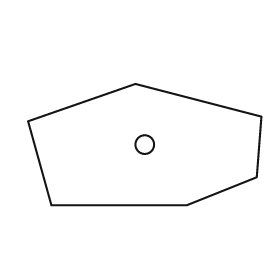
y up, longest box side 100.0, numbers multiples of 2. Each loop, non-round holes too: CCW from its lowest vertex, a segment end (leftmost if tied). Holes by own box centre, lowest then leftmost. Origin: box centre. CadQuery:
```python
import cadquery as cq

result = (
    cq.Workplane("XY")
    .moveTo(-40.0, -26.0)
    .lineTo(18.0, -26.0)
    .lineTo(48.0, -14.0)
    .lineTo(50.0, 12.0)
    .lineTo(-4.0, 26.0)
    .lineTo(-50.0, 10.0)
    .close()
    .moveTo(0.0, 0.0)
    .circle(4.0)
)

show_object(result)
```